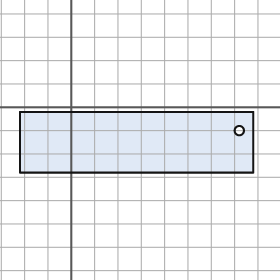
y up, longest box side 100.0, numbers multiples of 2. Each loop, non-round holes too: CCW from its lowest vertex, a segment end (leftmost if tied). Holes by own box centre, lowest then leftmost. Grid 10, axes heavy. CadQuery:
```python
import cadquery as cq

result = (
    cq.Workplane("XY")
    .moveTo(-22.0, -28.0)
    .lineTo(78.0, -28.0)
    .lineTo(78.0, -2.0)
    .lineTo(-22.0, -2.0)
    .close()
    .moveTo(72.0, -10.0)
    .circle(2.0)
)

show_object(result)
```